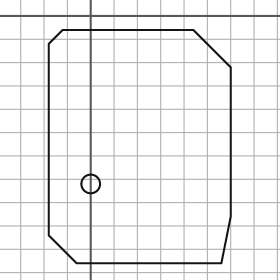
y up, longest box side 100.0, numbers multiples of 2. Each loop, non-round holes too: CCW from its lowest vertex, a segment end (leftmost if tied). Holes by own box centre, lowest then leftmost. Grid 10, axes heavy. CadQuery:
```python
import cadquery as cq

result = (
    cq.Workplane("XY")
    .moveTo(-6.0, -106.0)
    .lineTo(56.0, -106.0)
    .lineTo(60.0, -86.0)
    .lineTo(60.0, -22.0)
    .lineTo(44.0, -6.0)
    .lineTo(-12.0, -6.0)
    .lineTo(-18.0, -12.0)
    .lineTo(-18.0, -94.0)
    .close()
    .moveTo(0.0, -72.0)
    .circle(4.0)
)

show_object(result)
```